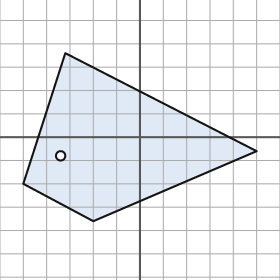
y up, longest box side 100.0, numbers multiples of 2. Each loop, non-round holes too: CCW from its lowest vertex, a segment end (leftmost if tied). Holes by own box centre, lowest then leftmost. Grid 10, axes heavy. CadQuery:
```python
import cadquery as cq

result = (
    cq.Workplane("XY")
    .moveTo(-20.0, -36.0)
    .lineTo(50.0, -6.0)
    .lineTo(-32.0, 36.0)
    .lineTo(-50.0, -20.0)
    .close()
    .moveTo(-34.0, -8.0)
    .circle(2.0)
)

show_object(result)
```